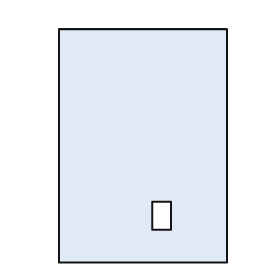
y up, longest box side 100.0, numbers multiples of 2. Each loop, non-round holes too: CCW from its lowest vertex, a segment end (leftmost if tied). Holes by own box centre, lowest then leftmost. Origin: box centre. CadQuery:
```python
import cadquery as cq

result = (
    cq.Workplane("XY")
    .moveTo(-36.0, -50.0)
    .lineTo(36.0, -50.0)
    .lineTo(36.0, 50.0)
    .lineTo(-36.0, 50.0)
    .close()
    .moveTo(4.0, -36.0)
    .lineTo(12.0, -36.0)
    .lineTo(12.0, -24.0)
    .lineTo(4.0, -24.0)
    .close()
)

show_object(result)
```